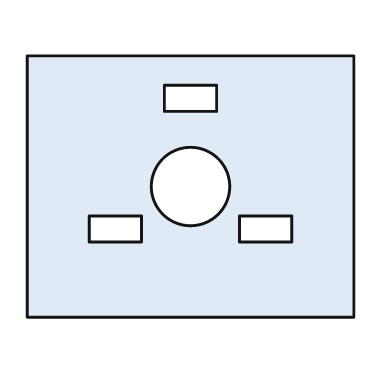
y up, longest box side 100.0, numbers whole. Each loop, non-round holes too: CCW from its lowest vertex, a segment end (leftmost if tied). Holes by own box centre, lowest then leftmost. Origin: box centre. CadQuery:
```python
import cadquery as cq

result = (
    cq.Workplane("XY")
    .moveTo(-50.0, -40.0)
    .lineTo(50.0, -40.0)
    .lineTo(50.0, 40.0)
    .lineTo(-50.0, 40.0)
    .close()
    .moveTo(-31.0, -17.0)
    .lineTo(-15.0, -17.0)
    .lineTo(-15.0, -9.0)
    .lineTo(-31.0, -9.0)
    .close()
    .moveTo(15.0, -17.0)
    .lineTo(31.0, -17.0)
    .lineTo(31.0, -9.0)
    .lineTo(15.0, -9.0)
    .close()
    .moveTo(0.0, 0.0)
    .circle(12.0)
    .moveTo(-8.0, 23.0)
    .lineTo(8.0, 23.0)
    .lineTo(8.0, 31.0)
    .lineTo(-8.0, 31.0)
    .close()
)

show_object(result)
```